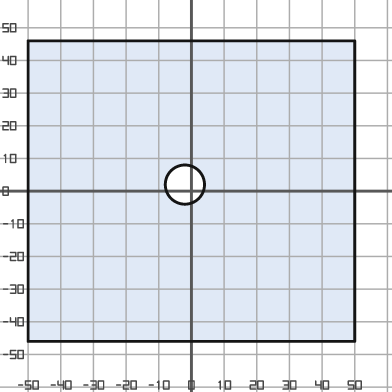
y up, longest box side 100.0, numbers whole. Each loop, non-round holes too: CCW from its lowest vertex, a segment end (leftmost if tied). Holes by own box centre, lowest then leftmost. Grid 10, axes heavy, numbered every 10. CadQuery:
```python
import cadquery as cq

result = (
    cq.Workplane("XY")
    .moveTo(-50.0, -46.0)
    .lineTo(50.0, -46.0)
    .lineTo(50.0, 46.0)
    .lineTo(-50.0, 46.0)
    .close()
    .moveTo(-2.0, 2.0)
    .circle(6.0)
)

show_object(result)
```